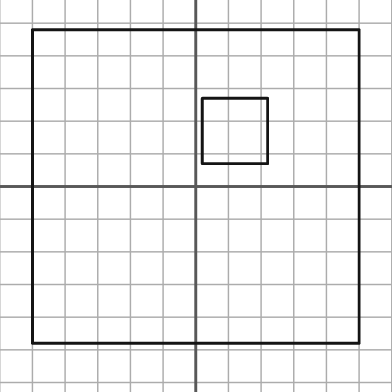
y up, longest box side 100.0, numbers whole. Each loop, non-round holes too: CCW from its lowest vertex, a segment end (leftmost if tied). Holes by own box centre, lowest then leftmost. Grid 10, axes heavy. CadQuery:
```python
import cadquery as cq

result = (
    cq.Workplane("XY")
    .moveTo(-50.0, -48.0)
    .lineTo(50.0, -48.0)
    .lineTo(50.0, 48.0)
    .lineTo(-50.0, 48.0)
    .close()
    .moveTo(2.0, 7.0)
    .lineTo(22.0, 7.0)
    .lineTo(22.0, 27.0)
    .lineTo(2.0, 27.0)
    .close()
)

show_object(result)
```